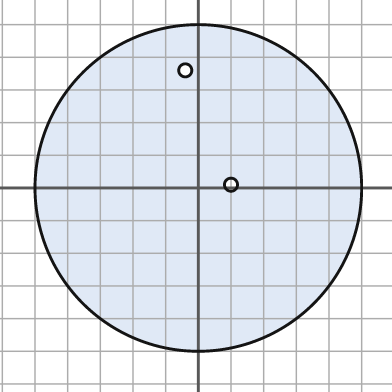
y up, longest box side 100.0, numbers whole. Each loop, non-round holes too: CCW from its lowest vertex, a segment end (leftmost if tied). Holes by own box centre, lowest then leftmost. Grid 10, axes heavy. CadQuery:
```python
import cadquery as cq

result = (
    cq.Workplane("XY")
    .moveTo(0.0, 0.0)
    .circle(50.0)
    .moveTo(10.0, 1.0)
    .circle(2.0)
    .moveTo(-4.0, 36.0)
    .circle(2.0)
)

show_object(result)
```